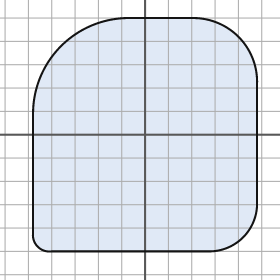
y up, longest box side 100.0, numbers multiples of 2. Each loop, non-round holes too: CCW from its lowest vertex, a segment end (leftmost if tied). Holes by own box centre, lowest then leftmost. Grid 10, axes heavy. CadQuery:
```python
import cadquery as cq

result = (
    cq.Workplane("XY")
    .moveTo(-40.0, -50.0)
    .lineTo(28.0, -50.0)
    .threePointArc((42.0, -44.0), (48.0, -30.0))
    .lineTo(48.0, 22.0)
    .threePointArc((40.0, 42.0), (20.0, 50.0))
    .lineTo(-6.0, 50.0)
    .threePointArc((-36.0, 38.0), (-48.0, 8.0))
    .lineTo(-48.0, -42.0)
    .threePointArc((-46.0, -48.0), (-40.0, -50.0))
    .close()
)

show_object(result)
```